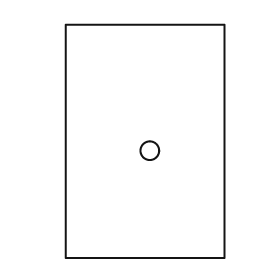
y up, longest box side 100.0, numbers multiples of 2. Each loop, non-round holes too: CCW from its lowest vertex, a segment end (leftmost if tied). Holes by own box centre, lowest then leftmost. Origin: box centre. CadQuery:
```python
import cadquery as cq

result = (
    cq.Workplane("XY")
    .moveTo(-34.0, -50.0)
    .lineTo(34.0, -50.0)
    .lineTo(34.0, 50.0)
    .lineTo(-34.0, 50.0)
    .close()
    .moveTo(2.0, -4.0)
    .circle(4.0)
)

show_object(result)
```